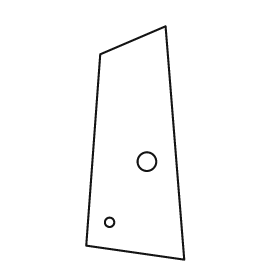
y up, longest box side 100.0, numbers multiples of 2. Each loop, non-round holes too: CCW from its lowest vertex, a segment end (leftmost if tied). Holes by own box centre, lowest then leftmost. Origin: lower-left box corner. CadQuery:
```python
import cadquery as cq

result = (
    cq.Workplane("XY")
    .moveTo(42.0, 0.0)
    .lineTo(34.0, 100.0)
    .lineTo(6.0, 88.0)
    .lineTo(0.0, 6.0)
    .close()
    .moveTo(10.0, 16.0)
    .circle(2.0)
    .moveTo(26.0, 42.0)
    .circle(4.0)
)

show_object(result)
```